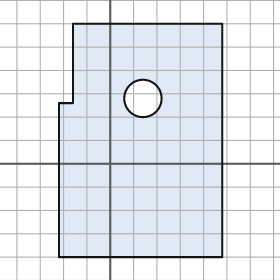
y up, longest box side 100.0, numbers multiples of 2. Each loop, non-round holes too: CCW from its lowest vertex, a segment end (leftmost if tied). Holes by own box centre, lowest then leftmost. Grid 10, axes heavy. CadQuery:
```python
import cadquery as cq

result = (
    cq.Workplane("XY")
    .moveTo(-22.0, -40.0)
    .lineTo(48.0, -40.0)
    .lineTo(48.0, 60.0)
    .lineTo(-16.0, 60.0)
    .lineTo(-16.0, 26.0)
    .lineTo(-22.0, 26.0)
    .close()
    .moveTo(14.0, 28.0)
    .circle(8.0)
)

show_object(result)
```